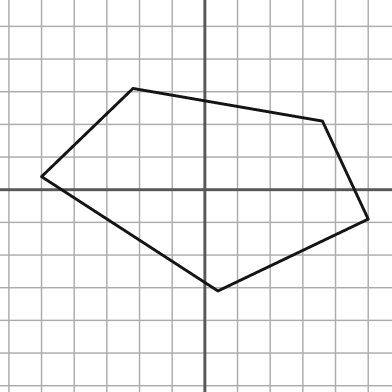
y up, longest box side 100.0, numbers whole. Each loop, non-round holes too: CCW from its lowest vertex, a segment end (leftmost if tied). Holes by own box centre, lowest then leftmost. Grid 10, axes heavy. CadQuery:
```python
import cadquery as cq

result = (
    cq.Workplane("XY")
    .moveTo(4.0, -31.0)
    .lineTo(50.0, -9.0)
    .lineTo(36.0, 21.0)
    .lineTo(-22.0, 31.0)
    .lineTo(-50.0, 4.0)
    .close()
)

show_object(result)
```